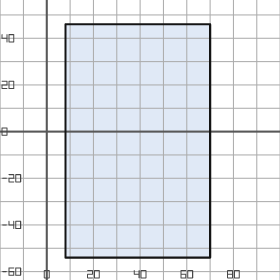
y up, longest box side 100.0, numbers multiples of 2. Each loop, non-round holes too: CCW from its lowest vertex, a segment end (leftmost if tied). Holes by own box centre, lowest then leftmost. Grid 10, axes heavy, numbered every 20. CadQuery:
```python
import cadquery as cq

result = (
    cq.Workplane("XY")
    .moveTo(8.0, -54.0)
    .lineTo(70.0, -54.0)
    .lineTo(70.0, 46.0)
    .lineTo(8.0, 46.0)
    .close()
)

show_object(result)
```